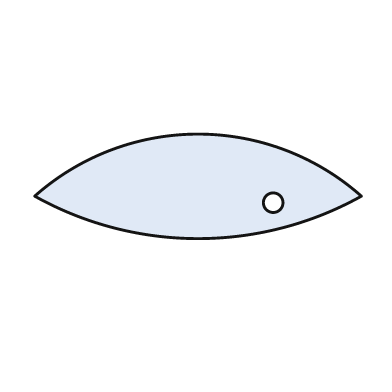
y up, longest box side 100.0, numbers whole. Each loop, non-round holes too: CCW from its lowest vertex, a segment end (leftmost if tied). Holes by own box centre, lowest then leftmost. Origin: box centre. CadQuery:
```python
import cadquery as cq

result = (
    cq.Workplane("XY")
    .moveTo(-50.0, -3.0)
    .threePointArc((0.0, -16.0), (50.0, -3.0))
    .threePointArc((0.0, 16.0), (-50.0, -3.0))
    .close()
    .moveTo(23.0, -5.0)
    .circle(3.0)
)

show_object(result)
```